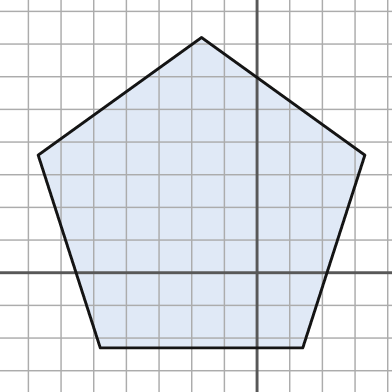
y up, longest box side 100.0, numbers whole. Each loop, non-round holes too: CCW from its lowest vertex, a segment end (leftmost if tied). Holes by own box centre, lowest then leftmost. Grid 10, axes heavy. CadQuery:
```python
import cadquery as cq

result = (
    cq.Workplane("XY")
    .moveTo(-48.0, -23.0)
    .lineTo(14.0, -23.0)
    .lineTo(33.0, 36.0)
    .lineTo(-17.0, 72.0)
    .lineTo(-67.0, 36.0)
    .close()
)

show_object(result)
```